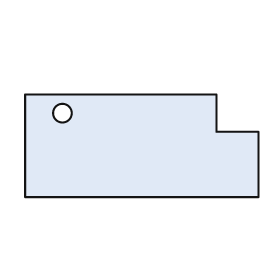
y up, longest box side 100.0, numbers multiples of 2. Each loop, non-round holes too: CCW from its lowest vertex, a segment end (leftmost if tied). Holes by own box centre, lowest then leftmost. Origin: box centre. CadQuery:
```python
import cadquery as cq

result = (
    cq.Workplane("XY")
    .moveTo(-50.0, -22.0)
    .lineTo(50.0, -22.0)
    .lineTo(50.0, 6.0)
    .lineTo(32.0, 6.0)
    .lineTo(32.0, 22.0)
    .lineTo(-50.0, 22.0)
    .close()
    .moveTo(-34.0, 14.0)
    .circle(4.0)
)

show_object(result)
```